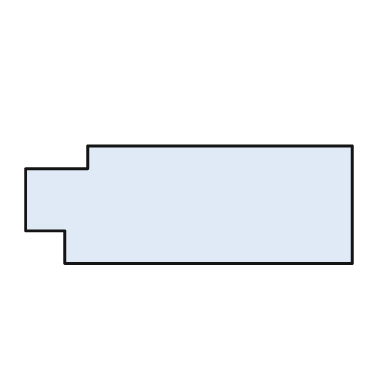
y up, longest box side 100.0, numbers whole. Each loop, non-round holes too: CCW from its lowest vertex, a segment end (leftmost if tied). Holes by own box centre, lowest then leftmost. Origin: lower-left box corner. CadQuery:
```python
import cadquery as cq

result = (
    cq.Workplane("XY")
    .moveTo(12.0, 0.0)
    .lineTo(100.0, 0.0)
    .lineTo(100.0, 36.0)
    .lineTo(19.0, 36.0)
    .lineTo(19.0, 29.0)
    .lineTo(0.0, 29.0)
    .lineTo(0.0, 10.0)
    .lineTo(12.0, 10.0)
    .close()
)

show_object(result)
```